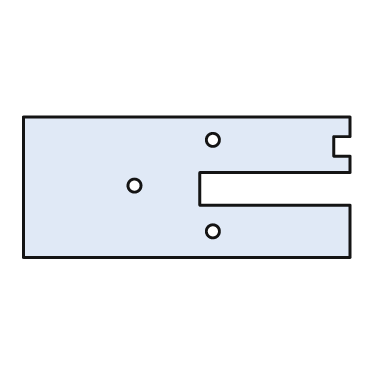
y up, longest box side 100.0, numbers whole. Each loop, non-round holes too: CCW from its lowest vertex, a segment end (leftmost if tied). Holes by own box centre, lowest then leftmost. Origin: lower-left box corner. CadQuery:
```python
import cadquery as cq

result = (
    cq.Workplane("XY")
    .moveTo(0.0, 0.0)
    .lineTo(100.0, 0.0)
    .lineTo(100.0, 16.0)
    .lineTo(54.0, 16.0)
    .lineTo(54.0, 26.0)
    .lineTo(100.0, 26.0)
    .lineTo(100.0, 31.0)
    .lineTo(95.0, 31.0)
    .lineTo(95.0, 37.0)
    .lineTo(100.0, 37.0)
    .lineTo(100.0, 43.0)
    .lineTo(0.0, 43.0)
    .close()
    .moveTo(58.0, 8.0)
    .circle(2.0)
    .moveTo(34.0, 22.0)
    .circle(2.0)
    .moveTo(58.0, 36.0)
    .circle(2.0)
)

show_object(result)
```